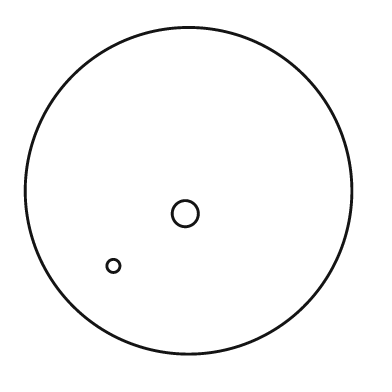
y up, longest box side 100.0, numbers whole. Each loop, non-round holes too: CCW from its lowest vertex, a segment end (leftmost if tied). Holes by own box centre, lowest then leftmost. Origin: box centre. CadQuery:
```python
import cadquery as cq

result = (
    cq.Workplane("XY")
    .moveTo(0.0, 0.0)
    .circle(50.0)
    .moveTo(-23.0, -23.0)
    .circle(2.0)
    .moveTo(-1.0, -7.0)
    .circle(4.0)
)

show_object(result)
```